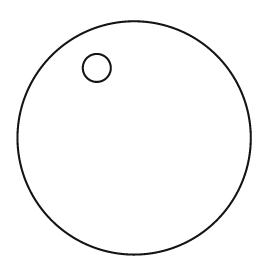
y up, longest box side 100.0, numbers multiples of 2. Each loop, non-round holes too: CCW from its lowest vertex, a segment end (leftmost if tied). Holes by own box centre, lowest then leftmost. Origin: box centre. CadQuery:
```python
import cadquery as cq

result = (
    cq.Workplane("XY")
    .moveTo(0.0, 0.0)
    .circle(50.0)
    .moveTo(-16.0, 30.0)
    .circle(6.0)
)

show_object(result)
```